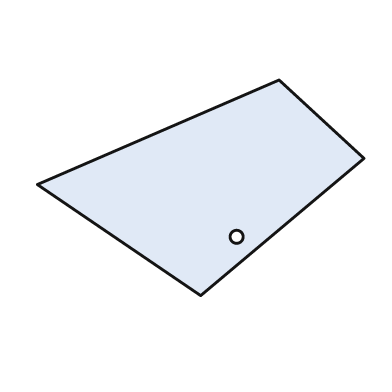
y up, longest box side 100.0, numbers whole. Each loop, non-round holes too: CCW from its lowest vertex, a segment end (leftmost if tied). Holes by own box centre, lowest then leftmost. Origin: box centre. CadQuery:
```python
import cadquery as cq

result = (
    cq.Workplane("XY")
    .moveTo(0.0, -33.0)
    .lineTo(50.0, 9.0)
    .lineTo(24.0, 33.0)
    .lineTo(-50.0, 1.0)
    .close()
    .moveTo(11.0, -15.0)
    .circle(2.0)
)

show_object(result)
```